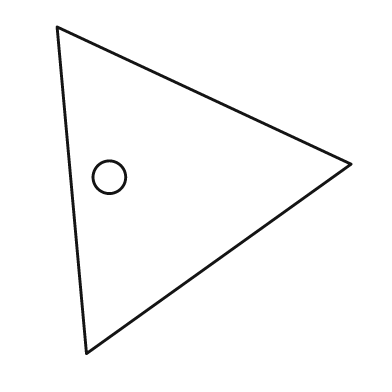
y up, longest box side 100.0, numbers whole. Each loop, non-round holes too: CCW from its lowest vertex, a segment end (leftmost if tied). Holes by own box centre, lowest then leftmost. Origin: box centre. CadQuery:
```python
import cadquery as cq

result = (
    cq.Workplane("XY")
    .moveTo(-36.0, -50.0)
    .lineTo(45.0, 8.0)
    .lineTo(-45.0, 50.0)
    .close()
    .moveTo(-29.0, 4.0)
    .circle(5.0)
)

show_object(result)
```